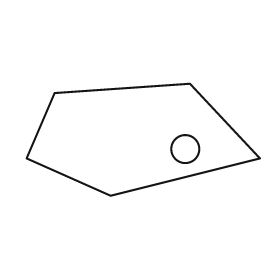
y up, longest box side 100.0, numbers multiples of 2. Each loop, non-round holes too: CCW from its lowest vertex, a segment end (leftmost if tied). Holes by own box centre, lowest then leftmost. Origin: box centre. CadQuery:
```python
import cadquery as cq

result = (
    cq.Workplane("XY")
    .moveTo(-14.0, -24.0)
    .lineTo(50.0, -8.0)
    .lineTo(20.0, 24.0)
    .lineTo(-38.0, 20.0)
    .lineTo(-50.0, -8.0)
    .close()
    .moveTo(18.0, -4.0)
    .circle(6.0)
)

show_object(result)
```